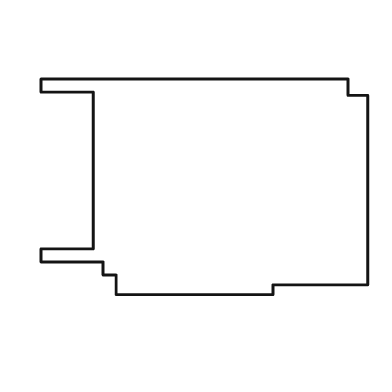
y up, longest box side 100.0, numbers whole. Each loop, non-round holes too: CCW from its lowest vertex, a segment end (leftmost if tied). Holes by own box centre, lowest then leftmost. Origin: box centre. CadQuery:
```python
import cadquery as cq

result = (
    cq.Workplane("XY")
    .moveTo(-27.0, -33.0)
    .lineTo(21.0, -33.0)
    .lineTo(21.0, -30.0)
    .lineTo(50.0, -30.0)
    .lineTo(50.0, 28.0)
    .lineTo(44.0, 28.0)
    .lineTo(44.0, 33.0)
    .lineTo(-50.0, 33.0)
    .lineTo(-50.0, 29.0)
    .lineTo(-34.0, 29.0)
    .lineTo(-34.0, -19.0)
    .lineTo(-50.0, -19.0)
    .lineTo(-50.0, -23.0)
    .lineTo(-31.0, -23.0)
    .lineTo(-31.0, -27.0)
    .lineTo(-27.0, -27.0)
    .close()
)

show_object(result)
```